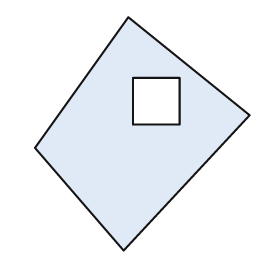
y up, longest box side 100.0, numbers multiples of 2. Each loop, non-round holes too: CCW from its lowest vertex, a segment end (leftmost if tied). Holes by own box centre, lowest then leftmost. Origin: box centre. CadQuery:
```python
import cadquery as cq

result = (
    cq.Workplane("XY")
    .moveTo(-8.0, -50.0)
    .lineTo(46.0, 8.0)
    .lineTo(-6.0, 50.0)
    .lineTo(-46.0, -6.0)
    .close()
    .moveTo(-4.0, 4.0)
    .lineTo(16.0, 4.0)
    .lineTo(16.0, 24.0)
    .lineTo(-4.0, 24.0)
    .close()
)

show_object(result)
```